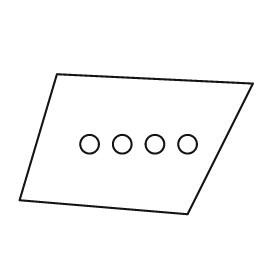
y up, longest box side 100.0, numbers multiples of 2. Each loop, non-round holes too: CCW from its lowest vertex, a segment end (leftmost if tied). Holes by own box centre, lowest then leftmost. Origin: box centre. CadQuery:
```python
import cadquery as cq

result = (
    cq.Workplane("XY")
    .moveTo(22.0, -30.0)
    .lineTo(50.0, 26.0)
    .lineTo(-34.0, 30.0)
    .lineTo(-50.0, -24.0)
    .close()
    .moveTo(-20.0, 0.0)
    .circle(4.0)
    .moveTo(-6.0, 0.0)
    .circle(4.0)
    .moveTo(8.0, 0.0)
    .circle(4.0)
    .moveTo(22.0, 0.0)
    .circle(4.0)
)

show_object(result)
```